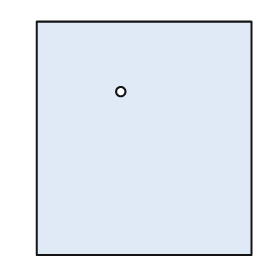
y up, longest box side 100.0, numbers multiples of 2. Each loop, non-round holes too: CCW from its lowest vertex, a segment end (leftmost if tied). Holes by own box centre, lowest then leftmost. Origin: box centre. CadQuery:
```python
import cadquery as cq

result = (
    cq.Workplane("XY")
    .moveTo(-46.0, -50.0)
    .lineTo(46.0, -50.0)
    .lineTo(46.0, 50.0)
    .lineTo(-46.0, 50.0)
    .close()
    .moveTo(-10.0, 20.0)
    .circle(2.0)
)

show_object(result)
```